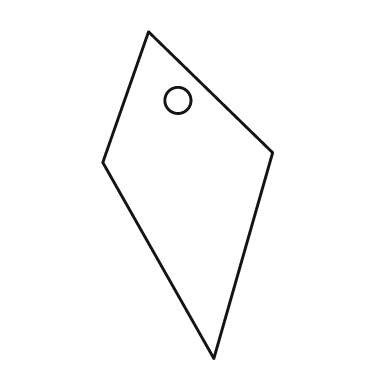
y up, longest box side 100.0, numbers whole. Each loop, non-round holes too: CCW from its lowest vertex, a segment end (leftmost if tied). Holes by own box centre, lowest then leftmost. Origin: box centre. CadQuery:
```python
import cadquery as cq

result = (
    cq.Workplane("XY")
    .moveTo(8.0, -50.0)
    .lineTo(26.0, 13.0)
    .lineTo(-12.0, 50.0)
    .lineTo(-26.0, 10.0)
    .close()
    .moveTo(-3.0, 29.0)
    .circle(4.0)
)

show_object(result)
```